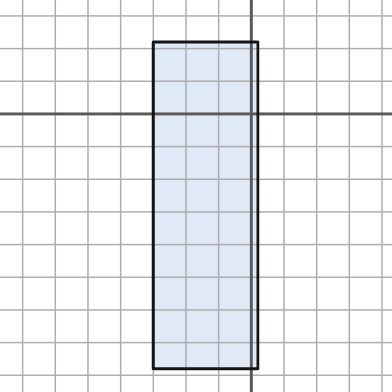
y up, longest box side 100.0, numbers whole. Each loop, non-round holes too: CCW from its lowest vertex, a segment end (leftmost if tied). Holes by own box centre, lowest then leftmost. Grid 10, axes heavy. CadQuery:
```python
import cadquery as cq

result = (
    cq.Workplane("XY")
    .moveTo(-30.0, -78.0)
    .lineTo(2.0, -78.0)
    .lineTo(2.0, 22.0)
    .lineTo(-30.0, 22.0)
    .close()
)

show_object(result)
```